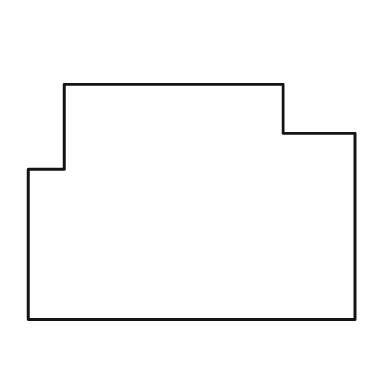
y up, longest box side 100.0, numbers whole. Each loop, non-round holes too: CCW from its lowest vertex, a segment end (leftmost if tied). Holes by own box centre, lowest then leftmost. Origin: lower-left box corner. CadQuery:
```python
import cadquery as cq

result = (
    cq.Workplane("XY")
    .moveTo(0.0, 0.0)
    .lineTo(100.0, 0.0)
    .lineTo(100.0, 57.0)
    .lineTo(78.0, 57.0)
    .lineTo(78.0, 72.0)
    .lineTo(11.0, 72.0)
    .lineTo(11.0, 46.0)
    .lineTo(0.0, 46.0)
    .close()
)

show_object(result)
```